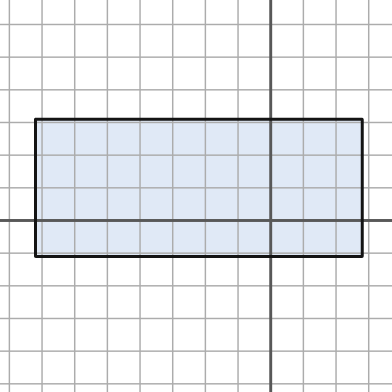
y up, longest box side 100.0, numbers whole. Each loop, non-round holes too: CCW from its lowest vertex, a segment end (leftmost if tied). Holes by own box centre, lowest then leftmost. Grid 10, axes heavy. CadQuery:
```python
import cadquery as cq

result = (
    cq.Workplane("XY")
    .moveTo(-72.0, -11.0)
    .lineTo(28.0, -11.0)
    .lineTo(28.0, 31.0)
    .lineTo(-72.0, 31.0)
    .close()
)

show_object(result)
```